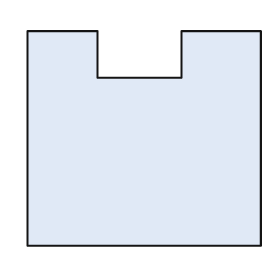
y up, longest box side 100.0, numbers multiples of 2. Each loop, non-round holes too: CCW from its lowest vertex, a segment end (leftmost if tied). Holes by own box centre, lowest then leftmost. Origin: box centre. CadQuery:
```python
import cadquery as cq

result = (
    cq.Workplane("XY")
    .moveTo(-50.0, -46.0)
    .lineTo(50.0, -46.0)
    .lineTo(50.0, 46.0)
    .lineTo(16.0, 46.0)
    .lineTo(16.0, 26.0)
    .lineTo(-20.0, 26.0)
    .lineTo(-20.0, 46.0)
    .lineTo(-50.0, 46.0)
    .close()
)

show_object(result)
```